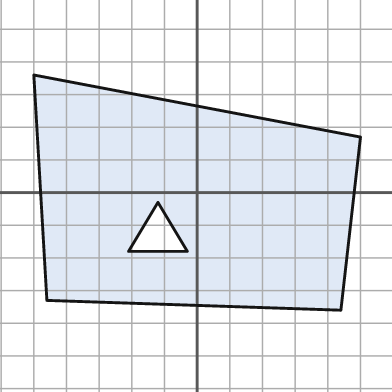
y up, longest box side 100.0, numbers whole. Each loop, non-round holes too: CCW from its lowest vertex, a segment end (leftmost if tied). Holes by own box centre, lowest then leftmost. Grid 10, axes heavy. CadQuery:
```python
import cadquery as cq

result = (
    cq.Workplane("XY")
    .moveTo(44.0, -36.0)
    .lineTo(50.0, 17.0)
    .lineTo(-50.0, 36.0)
    .lineTo(-46.0, -33.0)
    .close()
    .moveTo(-21.0, -18.0)
    .lineTo(-3.0, -18.0)
    .lineTo(-12.0, -3.0)
    .close()
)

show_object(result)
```